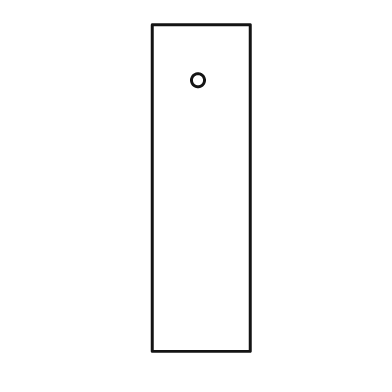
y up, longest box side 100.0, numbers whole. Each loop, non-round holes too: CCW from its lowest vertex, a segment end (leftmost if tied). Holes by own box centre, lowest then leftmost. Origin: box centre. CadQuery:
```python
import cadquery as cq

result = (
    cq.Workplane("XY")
    .moveTo(-15.0, -50.0)
    .lineTo(15.0, -50.0)
    .lineTo(15.0, 50.0)
    .lineTo(-15.0, 50.0)
    .close()
    .moveTo(-1.0, 33.0)
    .circle(2.0)
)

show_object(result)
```